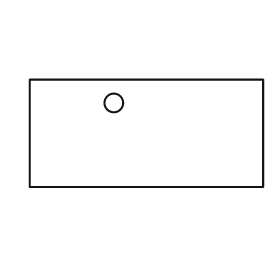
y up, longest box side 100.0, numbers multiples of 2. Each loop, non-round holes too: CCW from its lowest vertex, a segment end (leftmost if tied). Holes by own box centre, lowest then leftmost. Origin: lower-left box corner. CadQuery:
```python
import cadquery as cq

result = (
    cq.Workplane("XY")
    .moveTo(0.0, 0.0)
    .lineTo(100.0, 0.0)
    .lineTo(100.0, 46.0)
    .lineTo(0.0, 46.0)
    .close()
    .moveTo(36.0, 36.0)
    .circle(4.0)
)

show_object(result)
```